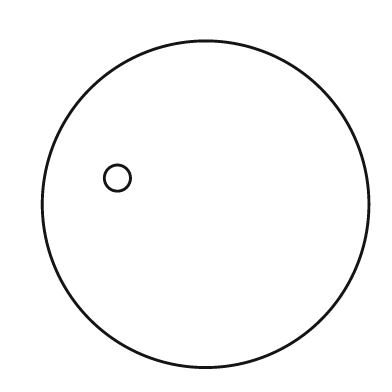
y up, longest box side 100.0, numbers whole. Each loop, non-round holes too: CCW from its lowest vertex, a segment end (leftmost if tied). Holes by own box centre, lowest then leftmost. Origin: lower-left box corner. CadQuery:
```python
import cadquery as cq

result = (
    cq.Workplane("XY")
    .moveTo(50.0, 50.0)
    .circle(50.0)
    .moveTo(23.0, 58.0)
    .circle(4.0)
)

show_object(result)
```